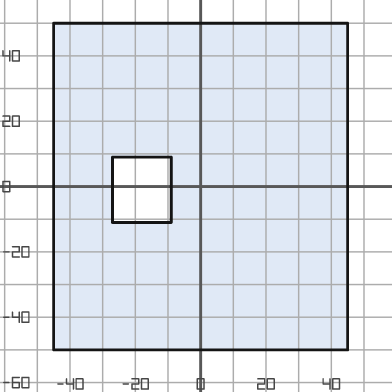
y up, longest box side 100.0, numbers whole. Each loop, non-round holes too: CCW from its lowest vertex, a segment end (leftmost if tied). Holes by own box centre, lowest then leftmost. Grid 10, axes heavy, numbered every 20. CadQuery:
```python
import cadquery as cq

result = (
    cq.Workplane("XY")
    .moveTo(-45.0, -50.0)
    .lineTo(45.0, -50.0)
    .lineTo(45.0, 50.0)
    .lineTo(-45.0, 50.0)
    .close()
    .moveTo(-27.0, -11.0)
    .lineTo(-9.0, -11.0)
    .lineTo(-9.0, 9.0)
    .lineTo(-27.0, 9.0)
    .close()
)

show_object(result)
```